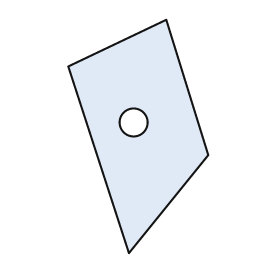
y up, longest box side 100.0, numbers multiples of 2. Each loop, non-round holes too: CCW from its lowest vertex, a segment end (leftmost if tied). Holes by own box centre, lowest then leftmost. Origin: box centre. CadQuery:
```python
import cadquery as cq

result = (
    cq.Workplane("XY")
    .moveTo(-4.0, -50.0)
    .lineTo(30.0, -8.0)
    .lineTo(12.0, 50.0)
    .lineTo(-30.0, 30.0)
    .close()
    .moveTo(-2.0, 6.0)
    .circle(6.0)
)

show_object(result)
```